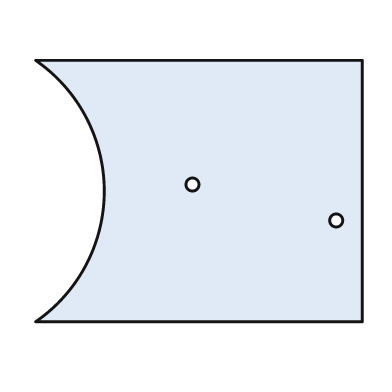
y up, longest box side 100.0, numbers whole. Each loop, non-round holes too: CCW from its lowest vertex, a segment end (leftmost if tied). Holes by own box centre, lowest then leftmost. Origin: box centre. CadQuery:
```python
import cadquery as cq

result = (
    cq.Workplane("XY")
    .moveTo(-50.0, -40.0)
    .lineTo(50.0, -40.0)
    .lineTo(50.0, 40.0)
    .lineTo(-50.0, 40.0)
    .threePointArc((-29.0, 0.0), (-50.0, -40.0))
    .close()
    .moveTo(42.0, -9.0)
    .circle(2.0)
    .moveTo(-2.0, 2.0)
    .circle(2.0)
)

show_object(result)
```